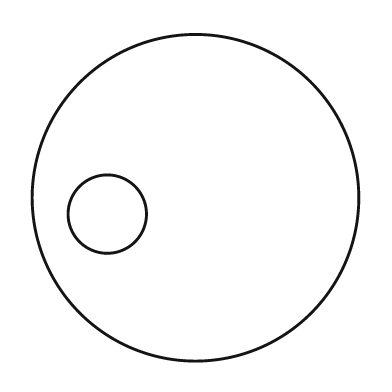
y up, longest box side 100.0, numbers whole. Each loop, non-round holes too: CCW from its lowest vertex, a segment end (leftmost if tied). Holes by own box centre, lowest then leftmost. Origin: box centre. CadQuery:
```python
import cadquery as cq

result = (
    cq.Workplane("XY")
    .moveTo(0.0, 0.0)
    .circle(50.0)
    .moveTo(-27.0, -5.0)
    .circle(12.0)
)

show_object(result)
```